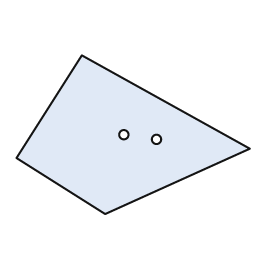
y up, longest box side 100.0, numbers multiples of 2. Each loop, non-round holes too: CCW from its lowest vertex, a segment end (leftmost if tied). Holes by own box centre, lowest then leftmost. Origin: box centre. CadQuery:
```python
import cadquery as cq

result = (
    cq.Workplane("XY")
    .moveTo(-12.0, -34.0)
    .lineTo(50.0, -6.0)
    .lineTo(-22.0, 34.0)
    .lineTo(-50.0, -10.0)
    .close()
    .moveTo(10.0, -2.0)
    .circle(2.0)
    .moveTo(-4.0, 0.0)
    .circle(2.0)
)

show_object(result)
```